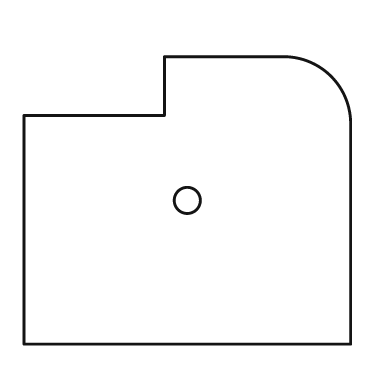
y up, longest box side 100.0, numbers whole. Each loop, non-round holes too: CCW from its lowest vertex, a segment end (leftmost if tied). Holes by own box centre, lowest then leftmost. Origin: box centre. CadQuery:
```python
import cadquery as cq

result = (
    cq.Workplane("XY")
    .moveTo(-50.0, -44.0)
    .lineTo(50.0, -44.0)
    .lineTo(50.0, 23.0)
    .threePointArc((44.0, 38.0), (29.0, 44.0))
    .lineTo(-7.0, 44.0)
    .lineTo(-7.0, 26.0)
    .lineTo(-50.0, 26.0)
    .close()
    .moveTo(0.0, 0.0)
    .circle(4.0)
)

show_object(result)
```